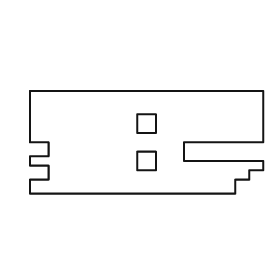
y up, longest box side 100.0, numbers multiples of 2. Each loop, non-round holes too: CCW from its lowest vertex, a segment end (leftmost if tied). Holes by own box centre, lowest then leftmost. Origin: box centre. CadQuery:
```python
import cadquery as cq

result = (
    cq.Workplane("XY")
    .moveTo(-50.0, -22.0)
    .lineTo(38.0, -22.0)
    .lineTo(38.0, -16.0)
    .lineTo(44.0, -16.0)
    .lineTo(44.0, -12.0)
    .lineTo(50.0, -12.0)
    .lineTo(50.0, -8.0)
    .lineTo(16.0, -8.0)
    .lineTo(16.0, 0.0)
    .lineTo(50.0, 0.0)
    .lineTo(50.0, 22.0)
    .lineTo(-50.0, 22.0)
    .lineTo(-50.0, 0.0)
    .lineTo(-42.0, 0.0)
    .lineTo(-42.0, -6.0)
    .lineTo(-50.0, -6.0)
    .lineTo(-50.0, -10.0)
    .lineTo(-42.0, -10.0)
    .lineTo(-42.0, -16.0)
    .lineTo(-50.0, -16.0)
    .close()
    .moveTo(-4.0, -12.0)
    .lineTo(4.0, -12.0)
    .lineTo(4.0, -4.0)
    .lineTo(-4.0, -4.0)
    .close()
    .moveTo(-4.0, 4.0)
    .lineTo(4.0, 4.0)
    .lineTo(4.0, 12.0)
    .lineTo(-4.0, 12.0)
    .close()
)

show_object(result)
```